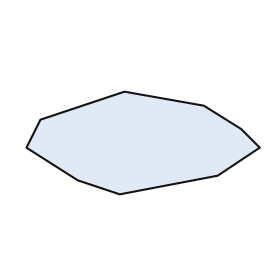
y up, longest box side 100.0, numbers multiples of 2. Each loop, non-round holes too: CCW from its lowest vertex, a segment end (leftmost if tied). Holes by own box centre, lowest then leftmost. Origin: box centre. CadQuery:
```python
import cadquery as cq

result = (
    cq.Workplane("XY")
    .moveTo(-10.0, -22.0)
    .lineTo(32.0, -14.0)
    .lineTo(50.0, -2.0)
    .lineTo(42.0, 6.0)
    .lineTo(26.0, 16.0)
    .lineTo(-8.0, 22.0)
    .lineTo(-44.0, 10.0)
    .lineTo(-50.0, -2.0)
    .lineTo(-28.0, -16.0)
    .close()
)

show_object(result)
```